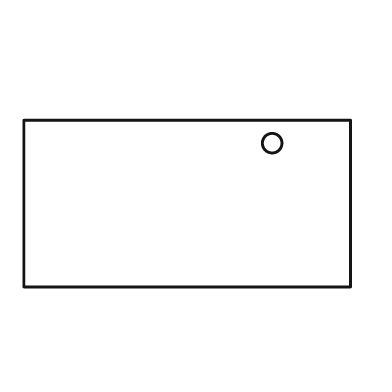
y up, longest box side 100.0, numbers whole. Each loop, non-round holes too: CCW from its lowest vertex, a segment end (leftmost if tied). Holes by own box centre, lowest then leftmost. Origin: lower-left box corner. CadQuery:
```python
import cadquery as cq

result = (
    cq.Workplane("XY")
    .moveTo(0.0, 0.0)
    .lineTo(100.0, 0.0)
    .lineTo(100.0, 51.0)
    .lineTo(0.0, 51.0)
    .close()
    .moveTo(76.0, 44.0)
    .circle(3.0)
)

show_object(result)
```